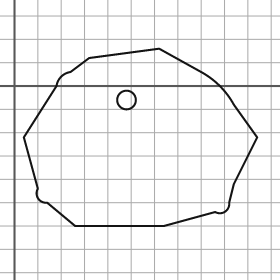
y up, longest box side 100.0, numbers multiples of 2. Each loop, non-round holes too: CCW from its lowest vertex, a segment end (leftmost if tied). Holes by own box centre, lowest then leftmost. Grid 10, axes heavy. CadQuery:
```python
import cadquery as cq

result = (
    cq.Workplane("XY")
    .moveTo(26.0, -60.0)
    .lineTo(64.0, -60.0)
    .lineTo(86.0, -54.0)
    .threePointArc((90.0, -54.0), (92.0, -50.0))
    .lineTo(94.0, -42.0)
    .lineTo(104.0, -22.0)
    .lineTo(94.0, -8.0)
    .threePointArc((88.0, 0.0), (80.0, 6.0))
    .lineTo(62.0, 16.0)
    .lineTo(32.0, 12.0)
    .lineTo(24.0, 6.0)
    .threePointArc((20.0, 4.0), (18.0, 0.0))
    .lineTo(4.0, -22.0)
    .lineTo(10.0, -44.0)
    .threePointArc((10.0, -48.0), (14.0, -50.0))
    .close()
    .moveTo(48.0, -6.0)
    .circle(4.0)
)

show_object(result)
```